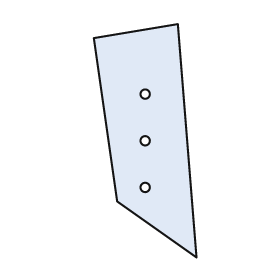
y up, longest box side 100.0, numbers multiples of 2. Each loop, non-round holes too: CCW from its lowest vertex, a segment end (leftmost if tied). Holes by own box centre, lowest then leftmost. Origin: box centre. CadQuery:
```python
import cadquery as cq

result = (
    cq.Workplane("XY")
    .moveTo(22.0, -50.0)
    .lineTo(14.0, 50.0)
    .lineTo(-22.0, 44.0)
    .lineTo(-12.0, -26.0)
    .close()
    .moveTo(0.0, -20.0)
    .circle(2.0)
    .moveTo(0.0, 0.0)
    .circle(2.0)
    .moveTo(0.0, 20.0)
    .circle(2.0)
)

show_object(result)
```